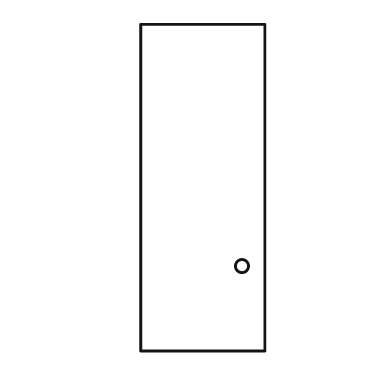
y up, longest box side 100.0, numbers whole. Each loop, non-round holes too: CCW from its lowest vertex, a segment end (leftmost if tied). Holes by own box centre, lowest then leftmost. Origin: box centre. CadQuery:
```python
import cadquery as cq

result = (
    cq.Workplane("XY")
    .moveTo(-19.0, -50.0)
    .lineTo(19.0, -50.0)
    .lineTo(19.0, 50.0)
    .lineTo(-19.0, 50.0)
    .close()
    .moveTo(12.0, -24.0)
    .circle(2.0)
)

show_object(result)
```